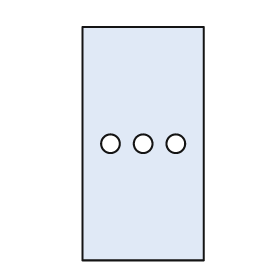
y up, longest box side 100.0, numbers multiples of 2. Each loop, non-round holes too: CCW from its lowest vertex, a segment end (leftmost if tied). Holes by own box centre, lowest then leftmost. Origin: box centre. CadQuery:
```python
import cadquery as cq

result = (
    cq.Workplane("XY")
    .moveTo(-26.0, -50.0)
    .lineTo(26.0, -50.0)
    .lineTo(26.0, 50.0)
    .lineTo(-26.0, 50.0)
    .close()
    .moveTo(-14.0, 0.0)
    .circle(4.0)
    .moveTo(0.0, 0.0)
    .circle(4.0)
    .moveTo(14.0, 0.0)
    .circle(4.0)
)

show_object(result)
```